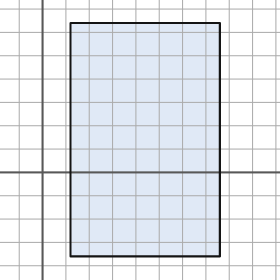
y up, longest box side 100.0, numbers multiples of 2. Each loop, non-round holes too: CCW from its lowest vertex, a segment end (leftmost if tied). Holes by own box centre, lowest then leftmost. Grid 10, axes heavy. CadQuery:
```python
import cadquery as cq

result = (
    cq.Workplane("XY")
    .moveTo(12.0, -36.0)
    .lineTo(76.0, -36.0)
    .lineTo(76.0, 64.0)
    .lineTo(12.0, 64.0)
    .close()
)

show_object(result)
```